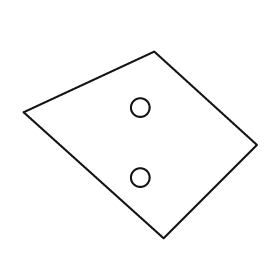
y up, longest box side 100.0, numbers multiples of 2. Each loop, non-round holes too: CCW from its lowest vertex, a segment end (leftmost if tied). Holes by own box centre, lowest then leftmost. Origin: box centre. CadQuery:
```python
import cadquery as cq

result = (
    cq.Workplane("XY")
    .moveTo(10.0, -40.0)
    .lineTo(50.0, 0.0)
    .lineTo(6.0, 40.0)
    .lineTo(-50.0, 14.0)
    .close()
    .moveTo(0.0, -14.0)
    .circle(4.0)
    .moveTo(0.0, 16.0)
    .circle(4.0)
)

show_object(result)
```